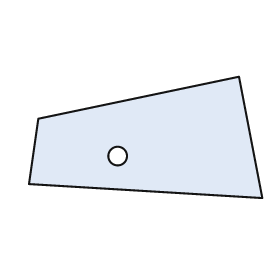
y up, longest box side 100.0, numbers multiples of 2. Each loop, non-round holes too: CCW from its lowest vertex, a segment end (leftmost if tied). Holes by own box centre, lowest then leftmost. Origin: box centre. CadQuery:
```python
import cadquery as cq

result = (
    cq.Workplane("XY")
    .moveTo(50.0, -26.0)
    .lineTo(40.0, 26.0)
    .lineTo(-46.0, 8.0)
    .lineTo(-50.0, -20.0)
    .close()
    .moveTo(-12.0, -8.0)
    .circle(4.0)
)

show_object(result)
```